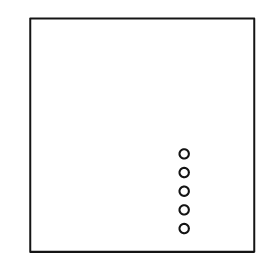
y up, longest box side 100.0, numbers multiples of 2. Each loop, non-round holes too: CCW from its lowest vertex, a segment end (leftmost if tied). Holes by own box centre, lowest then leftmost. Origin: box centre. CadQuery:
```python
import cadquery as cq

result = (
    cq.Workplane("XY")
    .moveTo(-48.0, -50.0)
    .lineTo(48.0, -50.0)
    .lineTo(48.0, 50.0)
    .lineTo(-48.0, 50.0)
    .close()
    .moveTo(18.0, -40.0)
    .circle(2.0)
    .moveTo(18.0, -32.0)
    .circle(2.0)
    .moveTo(18.0, -24.0)
    .circle(2.0)
    .moveTo(18.0, -16.0)
    .circle(2.0)
    .moveTo(18.0, -8.0)
    .circle(2.0)
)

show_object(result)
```